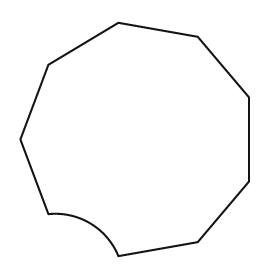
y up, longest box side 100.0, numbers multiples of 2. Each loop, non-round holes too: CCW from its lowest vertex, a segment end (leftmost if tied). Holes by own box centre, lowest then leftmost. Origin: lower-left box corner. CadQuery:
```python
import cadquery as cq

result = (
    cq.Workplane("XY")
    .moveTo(42.0, 0.0)
    .lineTo(76.0, 6.0)
    .lineTo(98.0, 32.0)
    .lineTo(98.0, 68.0)
    .lineTo(76.0, 94.0)
    .lineTo(42.0, 100.0)
    .lineTo(12.0, 82.0)
    .lineTo(0.0, 50.0)
    .lineTo(12.0, 18.0)
    .threePointArc((30.0, 14.0), (42.0, 0.0))
    .close()
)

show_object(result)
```